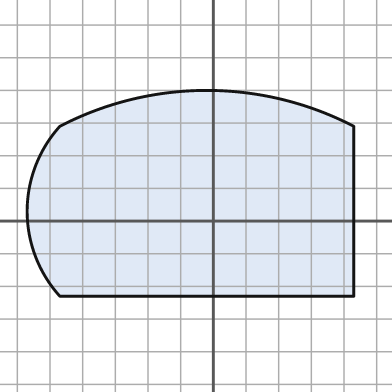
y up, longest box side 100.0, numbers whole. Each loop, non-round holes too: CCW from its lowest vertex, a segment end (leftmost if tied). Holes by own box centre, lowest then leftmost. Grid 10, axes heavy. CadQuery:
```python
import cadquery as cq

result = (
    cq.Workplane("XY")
    .moveTo(-47.0, -23.0)
    .lineTo(43.0, -23.0)
    .lineTo(43.0, 29.0)
    .threePointArc((-2.0, 40.0), (-47.0, 29.0))
    .threePointArc((-57.0, 3.0), (-47.0, -23.0))
    .close()
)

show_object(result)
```